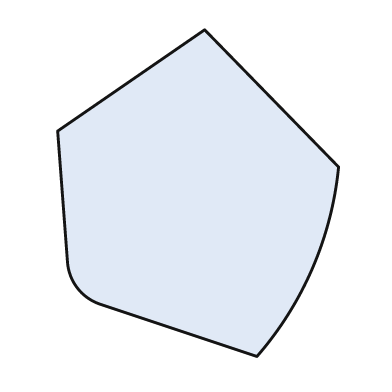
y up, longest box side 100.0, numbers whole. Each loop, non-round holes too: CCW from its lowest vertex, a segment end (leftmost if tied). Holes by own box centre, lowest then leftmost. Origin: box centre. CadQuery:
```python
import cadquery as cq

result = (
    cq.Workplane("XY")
    .moveTo(18.0, -50.0)
    .threePointArc((35.0, -23.0), (43.0, 8.0))
    .lineTo(2.0, 50.0)
    .lineTo(-43.0, 19.0)
    .lineTo(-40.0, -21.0)
    .threePointArc((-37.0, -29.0), (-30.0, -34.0))
    .close()
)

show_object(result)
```